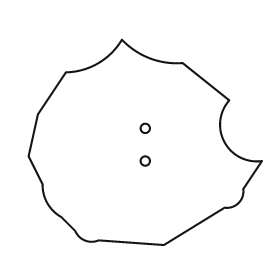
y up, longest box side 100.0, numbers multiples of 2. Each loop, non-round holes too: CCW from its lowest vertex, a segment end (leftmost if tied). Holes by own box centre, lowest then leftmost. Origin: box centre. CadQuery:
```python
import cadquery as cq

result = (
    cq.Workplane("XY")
    .moveTo(8.0, -44.0)
    .lineTo(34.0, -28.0)
    .threePointArc((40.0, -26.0), (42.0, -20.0))
    .lineTo(50.0, -8.0)
    .threePointArc((34.0, 0.0), (36.0, 18.0))
    .lineTo(16.0, 34.0)
    .threePointArc((2.0, 36.0), (-10.0, 44.0))
    .threePointArc((-20.0, 34.0), (-34.0, 30.0))
    .lineTo(-46.0, 12.0)
    .lineTo(-50.0, -6.0)
    .lineTo(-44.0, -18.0)
    .threePointArc((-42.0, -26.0), (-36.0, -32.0))
    .lineTo(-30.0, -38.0)
    .threePointArc((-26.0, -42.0), (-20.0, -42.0))
    .close()
    .moveTo(0.0, -8.0)
    .circle(2.0)
    .moveTo(0.0, 6.0)
    .circle(2.0)
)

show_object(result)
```